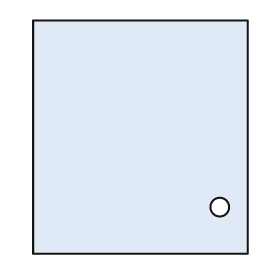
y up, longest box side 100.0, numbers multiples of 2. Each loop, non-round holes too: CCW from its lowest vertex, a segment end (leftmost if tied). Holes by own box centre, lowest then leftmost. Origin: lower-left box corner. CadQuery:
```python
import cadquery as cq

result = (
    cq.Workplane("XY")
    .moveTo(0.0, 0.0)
    .lineTo(92.0, 0.0)
    .lineTo(92.0, 100.0)
    .lineTo(0.0, 100.0)
    .close()
    .moveTo(80.0, 20.0)
    .circle(4.0)
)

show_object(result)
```